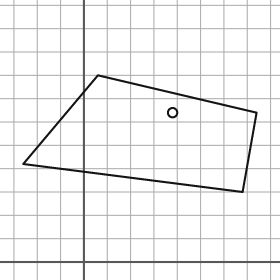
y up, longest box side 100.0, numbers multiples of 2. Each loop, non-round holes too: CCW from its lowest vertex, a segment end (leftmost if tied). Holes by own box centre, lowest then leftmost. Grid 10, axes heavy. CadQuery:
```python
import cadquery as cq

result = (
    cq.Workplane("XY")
    .moveTo(68.0, 30.0)
    .lineTo(74.0, 64.0)
    .lineTo(6.0, 80.0)
    .lineTo(-26.0, 42.0)
    .close()
    .moveTo(38.0, 64.0)
    .circle(2.0)
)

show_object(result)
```